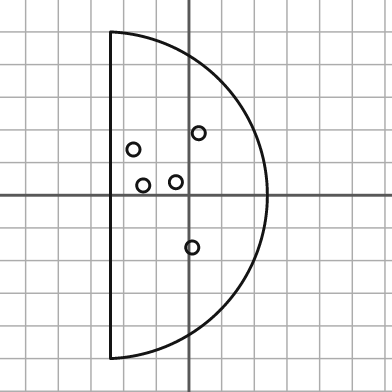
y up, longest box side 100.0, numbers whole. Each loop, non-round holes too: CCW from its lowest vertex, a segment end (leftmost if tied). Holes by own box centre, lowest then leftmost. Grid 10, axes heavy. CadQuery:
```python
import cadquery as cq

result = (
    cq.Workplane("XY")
    .moveTo(-24.0, -50.0)
    .threePointArc((24.0, 0.0), (-24.0, 50.0))
    .close()
    .moveTo(1.0, -16.0)
    .circle(2.0)
    .moveTo(-14.0, 3.0)
    .circle(2.0)
    .moveTo(-4.0, 4.0)
    .circle(2.0)
    .moveTo(-17.0, 14.0)
    .circle(2.0)
    .moveTo(3.0, 19.0)
    .circle(2.0)
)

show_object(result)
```